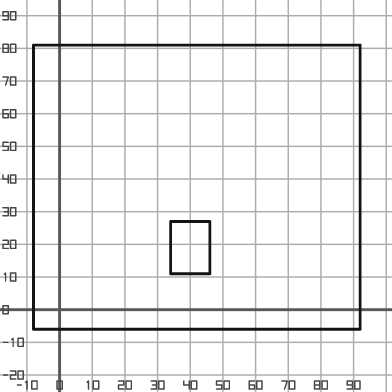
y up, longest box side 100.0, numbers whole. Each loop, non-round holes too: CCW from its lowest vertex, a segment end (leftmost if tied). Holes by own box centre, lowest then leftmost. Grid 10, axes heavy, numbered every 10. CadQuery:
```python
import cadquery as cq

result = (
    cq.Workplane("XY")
    .moveTo(-8.0, -6.0)
    .lineTo(92.0, -6.0)
    .lineTo(92.0, 81.0)
    .lineTo(-8.0, 81.0)
    .close()
    .moveTo(34.0, 11.0)
    .lineTo(46.0, 11.0)
    .lineTo(46.0, 27.0)
    .lineTo(34.0, 27.0)
    .close()
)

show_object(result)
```